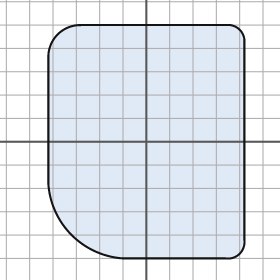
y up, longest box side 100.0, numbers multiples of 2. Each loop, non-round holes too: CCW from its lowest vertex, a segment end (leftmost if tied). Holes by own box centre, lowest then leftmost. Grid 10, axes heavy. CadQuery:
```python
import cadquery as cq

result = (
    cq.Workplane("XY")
    .moveTo(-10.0, -50.0)
    .lineTo(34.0, -50.0)
    .threePointArc((40.0, -48.0), (42.0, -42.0))
    .lineTo(42.0, 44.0)
    .threePointArc((40.0, 48.0), (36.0, 50.0))
    .lineTo(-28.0, 50.0)
    .threePointArc((-38.0, 46.0), (-42.0, 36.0))
    .lineTo(-42.0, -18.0)
    .threePointArc((-32.0, -40.0), (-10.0, -50.0))
    .close()
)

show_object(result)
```